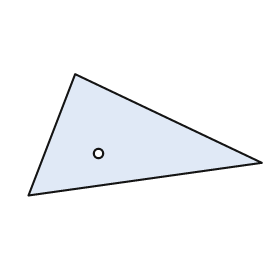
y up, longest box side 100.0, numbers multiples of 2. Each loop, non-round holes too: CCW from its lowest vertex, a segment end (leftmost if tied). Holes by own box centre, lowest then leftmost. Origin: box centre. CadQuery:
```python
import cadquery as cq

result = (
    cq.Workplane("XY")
    .moveTo(-50.0, -26.0)
    .lineTo(50.0, -12.0)
    .lineTo(-30.0, 26.0)
    .close()
    .moveTo(-20.0, -8.0)
    .circle(2.0)
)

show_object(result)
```